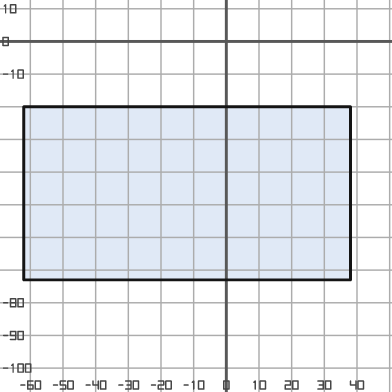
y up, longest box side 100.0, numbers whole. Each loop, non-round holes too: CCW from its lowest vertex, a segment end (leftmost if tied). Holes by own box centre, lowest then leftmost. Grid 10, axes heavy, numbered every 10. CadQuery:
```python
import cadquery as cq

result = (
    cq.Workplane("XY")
    .moveTo(-62.0, -73.0)
    .lineTo(38.0, -73.0)
    .lineTo(38.0, -20.0)
    .lineTo(-62.0, -20.0)
    .close()
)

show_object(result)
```